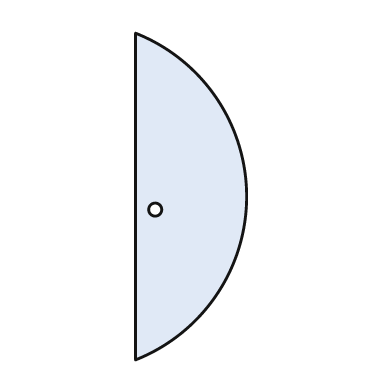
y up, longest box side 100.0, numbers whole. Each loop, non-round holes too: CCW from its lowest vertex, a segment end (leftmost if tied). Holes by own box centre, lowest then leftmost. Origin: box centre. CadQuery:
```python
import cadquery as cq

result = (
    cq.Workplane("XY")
    .moveTo(-17.0, -50.0)
    .threePointArc((17.0, 0.0), (-17.0, 50.0))
    .close()
    .moveTo(-11.0, -4.0)
    .circle(2.0)
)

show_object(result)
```